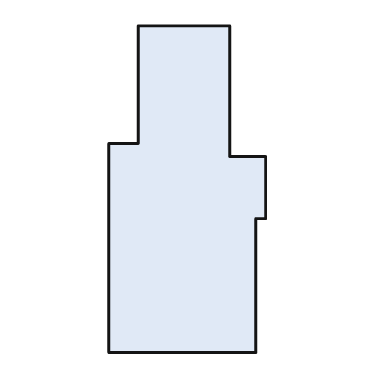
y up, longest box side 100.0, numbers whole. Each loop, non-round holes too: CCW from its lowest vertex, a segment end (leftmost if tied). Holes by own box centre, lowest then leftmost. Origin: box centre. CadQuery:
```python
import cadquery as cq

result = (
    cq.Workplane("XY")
    .moveTo(-24.0, -50.0)
    .lineTo(21.0, -50.0)
    .lineTo(21.0, -9.0)
    .lineTo(24.0, -9.0)
    .lineTo(24.0, 10.0)
    .lineTo(13.0, 10.0)
    .lineTo(13.0, 50.0)
    .lineTo(-15.0, 50.0)
    .lineTo(-15.0, 14.0)
    .lineTo(-24.0, 14.0)
    .close()
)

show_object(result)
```